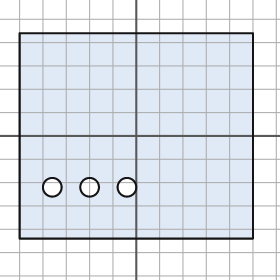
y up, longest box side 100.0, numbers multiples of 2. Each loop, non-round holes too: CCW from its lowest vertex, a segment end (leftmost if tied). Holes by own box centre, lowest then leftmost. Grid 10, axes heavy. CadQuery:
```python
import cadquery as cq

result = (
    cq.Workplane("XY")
    .moveTo(-50.0, -44.0)
    .lineTo(50.0, -44.0)
    .lineTo(50.0, 44.0)
    .lineTo(-50.0, 44.0)
    .close()
    .moveTo(-36.0, -22.0)
    .circle(4.0)
    .moveTo(-20.0, -22.0)
    .circle(4.0)
    .moveTo(-4.0, -22.0)
    .circle(4.0)
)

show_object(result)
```